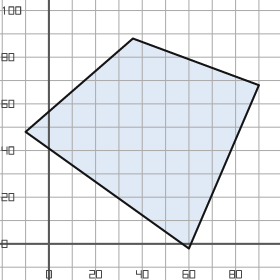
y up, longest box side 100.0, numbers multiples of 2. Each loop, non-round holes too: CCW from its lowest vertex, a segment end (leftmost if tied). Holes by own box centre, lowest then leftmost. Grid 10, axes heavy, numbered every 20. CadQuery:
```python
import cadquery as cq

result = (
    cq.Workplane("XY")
    .moveTo(60.0, -2.0)
    .lineTo(90.0, 68.0)
    .lineTo(36.0, 88.0)
    .lineTo(-10.0, 48.0)
    .close()
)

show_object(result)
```